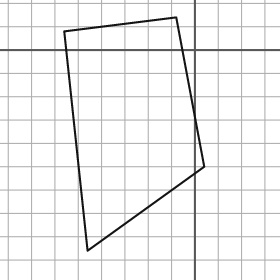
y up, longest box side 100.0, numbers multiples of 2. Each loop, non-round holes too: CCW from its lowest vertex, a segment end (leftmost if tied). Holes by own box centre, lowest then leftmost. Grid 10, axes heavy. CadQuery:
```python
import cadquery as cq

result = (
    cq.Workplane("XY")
    .moveTo(-46.0, -86.0)
    .lineTo(4.0, -50.0)
    .lineTo(-8.0, 14.0)
    .lineTo(-56.0, 8.0)
    .close()
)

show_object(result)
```